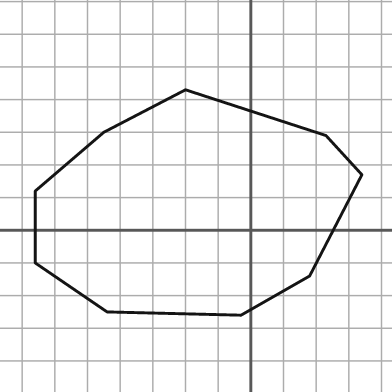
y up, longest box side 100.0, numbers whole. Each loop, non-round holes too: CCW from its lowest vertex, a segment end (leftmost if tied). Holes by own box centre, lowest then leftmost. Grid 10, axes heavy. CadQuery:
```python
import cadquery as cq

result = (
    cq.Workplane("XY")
    .moveTo(-3.0, -26.0)
    .lineTo(18.0, -14.0)
    .lineTo(34.0, 17.0)
    .lineTo(23.0, 29.0)
    .lineTo(-20.0, 43.0)
    .lineTo(-45.0, 30.0)
    .lineTo(-66.0, 12.0)
    .lineTo(-66.0, -10.0)
    .lineTo(-44.0, -25.0)
    .close()
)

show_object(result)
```